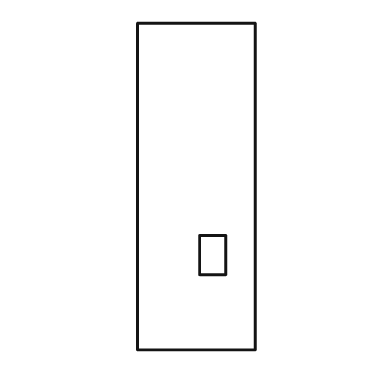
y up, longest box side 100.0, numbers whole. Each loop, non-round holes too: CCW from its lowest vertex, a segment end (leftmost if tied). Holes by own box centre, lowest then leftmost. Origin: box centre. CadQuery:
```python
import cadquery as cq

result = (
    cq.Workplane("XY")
    .moveTo(-18.0, -50.0)
    .lineTo(18.0, -50.0)
    .lineTo(18.0, 50.0)
    .lineTo(-18.0, 50.0)
    .close()
    .moveTo(1.0, -27.0)
    .lineTo(9.0, -27.0)
    .lineTo(9.0, -15.0)
    .lineTo(1.0, -15.0)
    .close()
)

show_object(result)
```